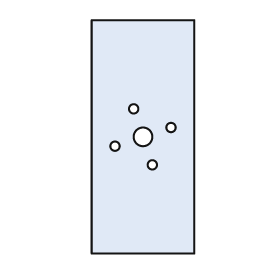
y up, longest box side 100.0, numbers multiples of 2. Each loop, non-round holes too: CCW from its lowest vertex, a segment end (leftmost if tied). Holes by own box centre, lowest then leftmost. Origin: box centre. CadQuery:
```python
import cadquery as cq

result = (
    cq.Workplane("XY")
    .moveTo(-22.0, -50.0)
    .lineTo(22.0, -50.0)
    .lineTo(22.0, 50.0)
    .lineTo(-22.0, 50.0)
    .close()
    .moveTo(4.0, -12.0)
    .circle(2.0)
    .moveTo(-12.0, -4.0)
    .circle(2.0)
    .moveTo(0.0, 0.0)
    .circle(4.0)
    .moveTo(12.0, 4.0)
    .circle(2.0)
    .moveTo(-4.0, 12.0)
    .circle(2.0)
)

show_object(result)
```